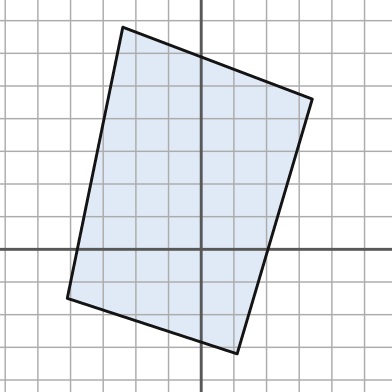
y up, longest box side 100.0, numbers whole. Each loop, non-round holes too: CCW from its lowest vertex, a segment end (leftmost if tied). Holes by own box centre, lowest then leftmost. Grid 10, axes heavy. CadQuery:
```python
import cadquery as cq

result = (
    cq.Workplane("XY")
    .moveTo(11.0, -32.0)
    .lineTo(34.0, 46.0)
    .lineTo(-24.0, 68.0)
    .lineTo(-41.0, -15.0)
    .close()
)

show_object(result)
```